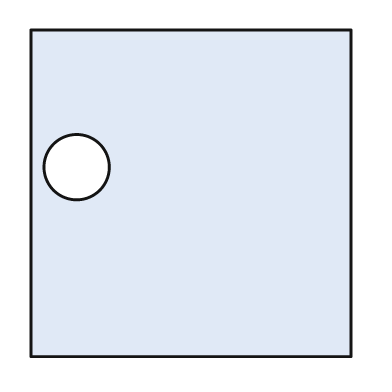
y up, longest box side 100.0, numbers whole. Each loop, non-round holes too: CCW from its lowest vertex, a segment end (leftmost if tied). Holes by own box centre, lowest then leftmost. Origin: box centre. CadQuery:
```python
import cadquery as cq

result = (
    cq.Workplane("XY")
    .moveTo(-49.0, -50.0)
    .lineTo(49.0, -50.0)
    .lineTo(49.0, 50.0)
    .lineTo(-49.0, 50.0)
    .close()
    .moveTo(-35.0, 8.0)
    .circle(10.0)
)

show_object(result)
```